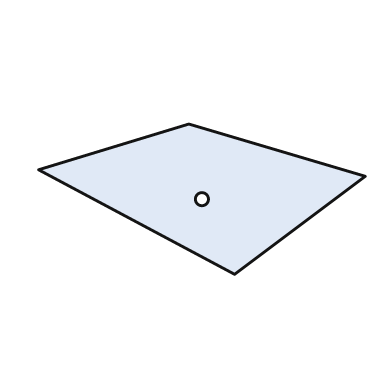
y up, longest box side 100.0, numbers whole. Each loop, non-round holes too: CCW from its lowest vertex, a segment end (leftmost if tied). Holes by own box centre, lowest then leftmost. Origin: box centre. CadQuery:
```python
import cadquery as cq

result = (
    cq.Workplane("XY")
    .moveTo(10.0, -23.0)
    .lineTo(50.0, 7.0)
    .lineTo(-4.0, 23.0)
    .lineTo(-50.0, 9.0)
    .close()
    .moveTo(0.0, 0.0)
    .circle(2.0)
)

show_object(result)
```